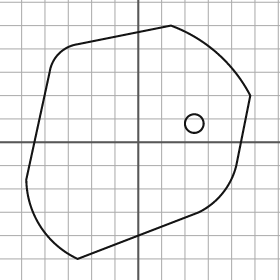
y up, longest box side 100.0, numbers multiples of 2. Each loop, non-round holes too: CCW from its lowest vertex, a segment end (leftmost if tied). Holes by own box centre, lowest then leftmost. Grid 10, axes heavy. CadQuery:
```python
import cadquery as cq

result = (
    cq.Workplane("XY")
    .moveTo(-26.0, -50.0)
    .lineTo(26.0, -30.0)
    .threePointArc((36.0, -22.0), (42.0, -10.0))
    .lineTo(48.0, 20.0)
    .threePointArc((34.0, 38.0), (14.0, 50.0))
    .lineTo(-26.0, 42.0)
    .threePointArc((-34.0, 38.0), (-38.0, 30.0))
    .lineTo(-48.0, -16.0)
    .threePointArc((-42.0, -36.0), (-26.0, -50.0))
    .close()
    .moveTo(24.0, 8.0)
    .circle(4.0)
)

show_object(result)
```